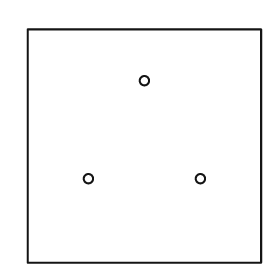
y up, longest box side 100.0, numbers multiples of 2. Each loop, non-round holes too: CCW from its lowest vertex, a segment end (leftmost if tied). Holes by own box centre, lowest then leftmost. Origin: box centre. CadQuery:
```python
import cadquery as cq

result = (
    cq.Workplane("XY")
    .moveTo(-50.0, -50.0)
    .lineTo(50.0, -50.0)
    .lineTo(50.0, 50.0)
    .lineTo(-50.0, 50.0)
    .close()
    .moveTo(-24.0, -14.0)
    .circle(2.0)
    .moveTo(24.0, -14.0)
    .circle(2.0)
    .moveTo(0.0, 28.0)
    .circle(2.0)
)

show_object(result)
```